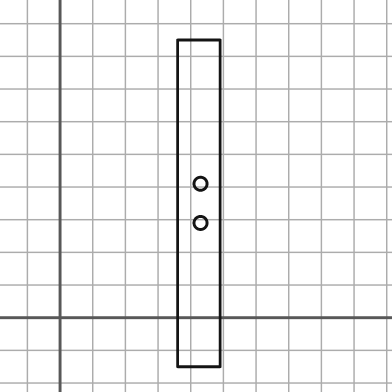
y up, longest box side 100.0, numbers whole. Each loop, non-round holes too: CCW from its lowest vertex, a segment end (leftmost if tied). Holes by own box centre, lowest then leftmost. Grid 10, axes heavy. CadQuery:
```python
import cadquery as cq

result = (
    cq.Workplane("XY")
    .moveTo(36.0, -15.0)
    .lineTo(49.0, -15.0)
    .lineTo(49.0, 85.0)
    .lineTo(36.0, 85.0)
    .close()
    .moveTo(43.0, 29.0)
    .circle(2.0)
    .moveTo(43.0, 41.0)
    .circle(2.0)
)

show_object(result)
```